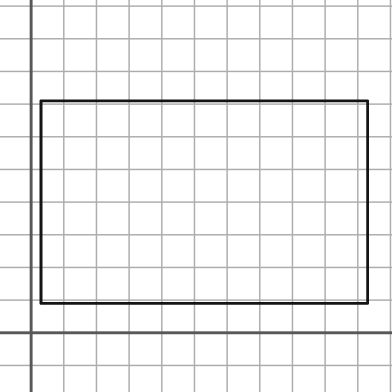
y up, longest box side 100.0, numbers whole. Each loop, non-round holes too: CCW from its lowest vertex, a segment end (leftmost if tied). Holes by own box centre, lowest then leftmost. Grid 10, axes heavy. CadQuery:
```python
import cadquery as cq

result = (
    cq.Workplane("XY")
    .moveTo(3.0, 9.0)
    .lineTo(103.0, 9.0)
    .lineTo(103.0, 71.0)
    .lineTo(3.0, 71.0)
    .close()
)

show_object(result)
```